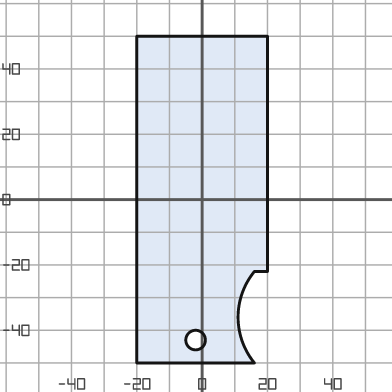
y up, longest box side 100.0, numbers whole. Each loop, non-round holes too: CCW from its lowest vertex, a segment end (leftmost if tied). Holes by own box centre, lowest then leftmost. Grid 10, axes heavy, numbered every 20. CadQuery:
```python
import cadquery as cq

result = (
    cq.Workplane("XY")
    .moveTo(-20.0, -50.0)
    .lineTo(16.0, -50.0)
    .threePointArc((11.0, -36.0), (16.0, -22.0))
    .lineTo(20.0, -22.0)
    .lineTo(20.0, 50.0)
    .lineTo(-20.0, 50.0)
    .close()
    .moveTo(-2.0, -43.0)
    .circle(3.0)
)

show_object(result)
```